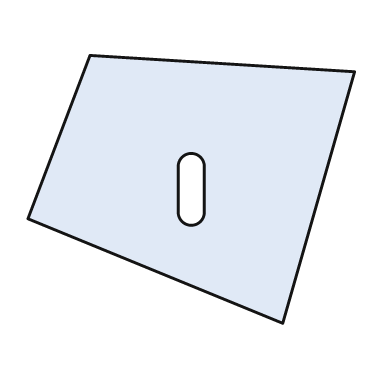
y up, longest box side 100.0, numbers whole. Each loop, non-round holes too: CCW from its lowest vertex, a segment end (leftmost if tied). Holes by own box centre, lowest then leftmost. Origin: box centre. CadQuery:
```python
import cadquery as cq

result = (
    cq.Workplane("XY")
    .moveTo(28.0, -41.0)
    .lineTo(50.0, 36.0)
    .lineTo(-31.0, 41.0)
    .lineTo(-50.0, -9.0)
    .close()
    .moveTo(-4.0, -7.0)
    .threePointArc((0.0, -11.0), (4.0, -7.0))
    .lineTo(4.0, 7.0)
    .threePointArc((0.0, 11.0), (-4.0, 7.0))
    .close()
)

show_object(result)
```